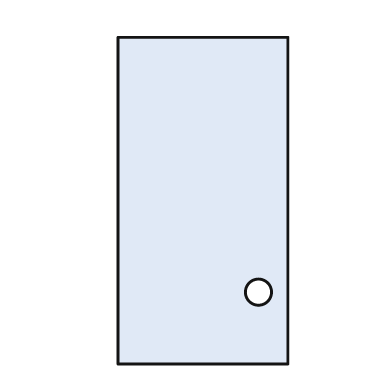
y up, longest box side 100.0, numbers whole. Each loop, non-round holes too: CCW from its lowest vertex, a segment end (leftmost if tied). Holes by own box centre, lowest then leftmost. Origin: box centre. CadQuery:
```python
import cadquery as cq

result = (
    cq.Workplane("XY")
    .moveTo(-26.0, -50.0)
    .lineTo(26.0, -50.0)
    .lineTo(26.0, 50.0)
    .lineTo(-26.0, 50.0)
    .close()
    .moveTo(17.0, -28.0)
    .circle(4.0)
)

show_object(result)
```